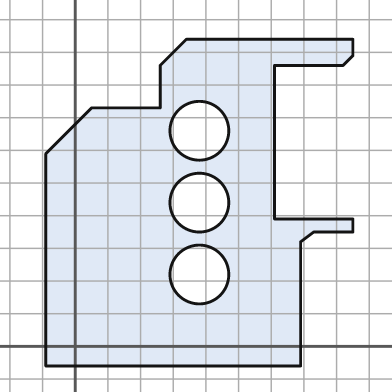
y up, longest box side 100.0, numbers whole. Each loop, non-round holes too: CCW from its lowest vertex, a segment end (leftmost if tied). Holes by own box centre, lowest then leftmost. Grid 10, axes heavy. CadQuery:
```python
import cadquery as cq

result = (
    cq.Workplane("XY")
    .moveTo(-9.0, -6.0)
    .lineTo(69.0, -6.0)
    .lineTo(69.0, 32.0)
    .lineTo(73.0, 35.0)
    .lineTo(85.0, 35.0)
    .lineTo(85.0, 39.0)
    .lineTo(61.0, 39.0)
    .lineTo(61.0, 86.0)
    .lineTo(82.0, 86.0)
    .lineTo(85.0, 89.0)
    .lineTo(85.0, 94.0)
    .lineTo(34.0, 94.0)
    .lineTo(26.0, 86.0)
    .lineTo(26.0, 73.0)
    .lineTo(5.0, 73.0)
    .lineTo(-9.0, 59.0)
    .close()
    .moveTo(38.0, 22.0)
    .circle(9.0)
    .moveTo(38.0, 44.0)
    .circle(9.0)
    .moveTo(38.0, 66.0)
    .circle(9.0)
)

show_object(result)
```